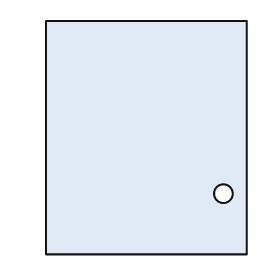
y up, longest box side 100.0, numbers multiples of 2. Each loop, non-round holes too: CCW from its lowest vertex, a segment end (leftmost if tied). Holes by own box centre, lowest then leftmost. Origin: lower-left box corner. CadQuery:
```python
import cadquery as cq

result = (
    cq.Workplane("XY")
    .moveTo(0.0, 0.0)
    .lineTo(86.0, 0.0)
    .lineTo(86.0, 100.0)
    .lineTo(0.0, 100.0)
    .close()
    .moveTo(76.0, 26.0)
    .circle(4.0)
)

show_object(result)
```